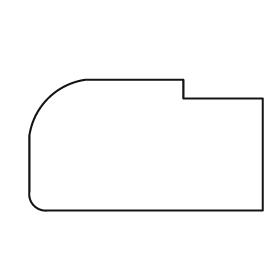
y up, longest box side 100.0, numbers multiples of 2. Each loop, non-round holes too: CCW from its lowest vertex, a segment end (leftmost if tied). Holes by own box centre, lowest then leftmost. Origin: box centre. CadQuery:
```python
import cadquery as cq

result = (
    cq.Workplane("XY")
    .moveTo(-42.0, -28.0)
    .lineTo(50.0, -28.0)
    .lineTo(50.0, 20.0)
    .lineTo(16.0, 20.0)
    .lineTo(16.0, 28.0)
    .lineTo(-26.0, 28.0)
    .threePointArc((-42.0, 20.0), (-50.0, 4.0))
    .lineTo(-50.0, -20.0)
    .threePointArc((-48.0, -26.0), (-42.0, -28.0))
    .close()
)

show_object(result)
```